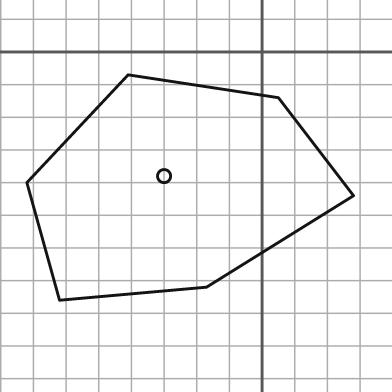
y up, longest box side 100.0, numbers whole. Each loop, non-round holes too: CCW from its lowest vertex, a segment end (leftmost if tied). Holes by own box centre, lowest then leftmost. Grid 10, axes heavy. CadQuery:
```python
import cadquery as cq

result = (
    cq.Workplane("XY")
    .moveTo(-62.0, -76.0)
    .lineTo(-17.0, -72.0)
    .lineTo(28.0, -44.0)
    .lineTo(5.0, -14.0)
    .lineTo(-41.0, -7.0)
    .lineTo(-72.0, -40.0)
    .close()
    .moveTo(-30.0, -38.0)
    .circle(2.0)
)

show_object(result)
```